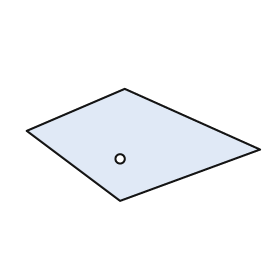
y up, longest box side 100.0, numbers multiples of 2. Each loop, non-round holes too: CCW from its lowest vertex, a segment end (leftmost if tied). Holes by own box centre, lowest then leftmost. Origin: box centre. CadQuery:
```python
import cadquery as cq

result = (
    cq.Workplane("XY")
    .moveTo(-10.0, -24.0)
    .lineTo(50.0, -2.0)
    .lineTo(-8.0, 24.0)
    .lineTo(-50.0, 6.0)
    .close()
    .moveTo(-10.0, -6.0)
    .circle(2.0)
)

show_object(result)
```